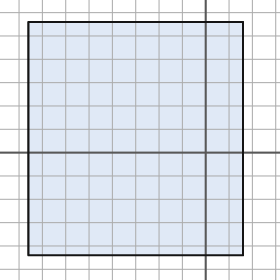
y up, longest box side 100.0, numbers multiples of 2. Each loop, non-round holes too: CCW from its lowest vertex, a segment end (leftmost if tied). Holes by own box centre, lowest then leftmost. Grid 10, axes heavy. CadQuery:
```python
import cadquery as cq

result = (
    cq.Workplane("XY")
    .moveTo(-76.0, -44.0)
    .lineTo(16.0, -44.0)
    .lineTo(16.0, 56.0)
    .lineTo(-76.0, 56.0)
    .close()
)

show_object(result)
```